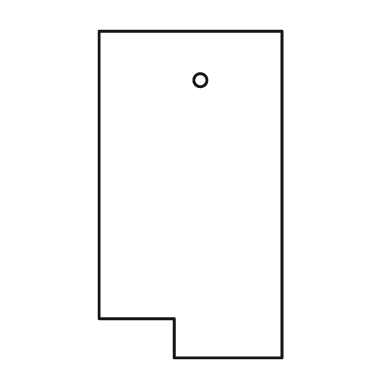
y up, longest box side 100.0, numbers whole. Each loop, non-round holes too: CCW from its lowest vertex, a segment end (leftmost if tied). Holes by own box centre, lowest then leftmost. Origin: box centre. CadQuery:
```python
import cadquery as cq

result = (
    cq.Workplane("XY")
    .moveTo(-5.0, -50.0)
    .lineTo(28.0, -50.0)
    .lineTo(28.0, 50.0)
    .lineTo(-28.0, 50.0)
    .lineTo(-28.0, -38.0)
    .lineTo(-5.0, -38.0)
    .close()
    .moveTo(3.0, 35.0)
    .circle(2.0)
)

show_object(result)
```